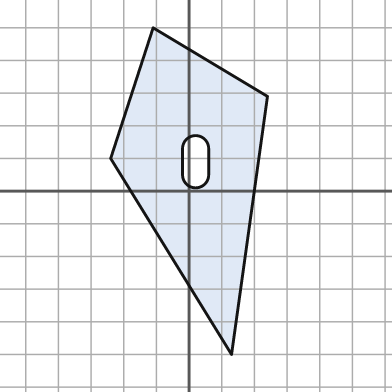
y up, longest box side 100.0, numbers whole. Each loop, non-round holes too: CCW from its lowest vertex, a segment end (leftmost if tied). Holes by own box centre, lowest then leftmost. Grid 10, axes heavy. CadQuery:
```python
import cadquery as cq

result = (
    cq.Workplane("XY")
    .moveTo(13.0, -50.0)
    .lineTo(24.0, 29.0)
    .lineTo(-11.0, 50.0)
    .lineTo(-24.0, 10.0)
    .close()
    .moveTo(-2.0, 5.0)
    .threePointArc((2.0, 1.0), (6.0, 5.0))
    .lineTo(6.0, 13.0)
    .threePointArc((2.0, 17.0), (-2.0, 13.0))
    .close()
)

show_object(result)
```